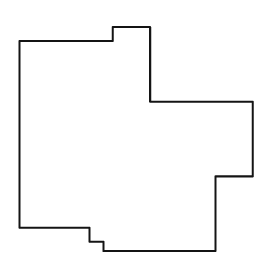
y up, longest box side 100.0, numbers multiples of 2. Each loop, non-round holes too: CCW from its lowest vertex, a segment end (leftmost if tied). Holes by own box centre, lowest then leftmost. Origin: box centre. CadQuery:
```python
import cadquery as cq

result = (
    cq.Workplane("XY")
    .moveTo(-14.0, -48.0)
    .lineTo(34.0, -48.0)
    .lineTo(34.0, -16.0)
    .lineTo(50.0, -16.0)
    .lineTo(50.0, 16.0)
    .lineTo(6.0, 16.0)
    .lineTo(6.0, 48.0)
    .lineTo(-10.0, 48.0)
    .lineTo(-10.0, 42.0)
    .lineTo(-50.0, 42.0)
    .lineTo(-50.0, -38.0)
    .lineTo(-20.0, -38.0)
    .lineTo(-20.0, -44.0)
    .lineTo(-14.0, -44.0)
    .close()
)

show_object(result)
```